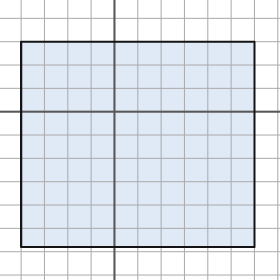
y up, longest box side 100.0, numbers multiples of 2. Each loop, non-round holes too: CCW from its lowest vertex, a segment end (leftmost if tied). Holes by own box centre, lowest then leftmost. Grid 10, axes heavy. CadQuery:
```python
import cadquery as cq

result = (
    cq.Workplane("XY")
    .moveTo(-40.0, -58.0)
    .lineTo(60.0, -58.0)
    .lineTo(60.0, 30.0)
    .lineTo(-40.0, 30.0)
    .close()
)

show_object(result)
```